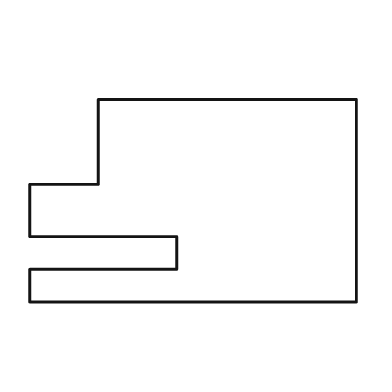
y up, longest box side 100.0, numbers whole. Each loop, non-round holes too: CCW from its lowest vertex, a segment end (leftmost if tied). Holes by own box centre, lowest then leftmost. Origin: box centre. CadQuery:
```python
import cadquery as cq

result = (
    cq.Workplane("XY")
    .moveTo(-50.0, -31.0)
    .lineTo(50.0, -31.0)
    .lineTo(50.0, 31.0)
    .lineTo(-29.0, 31.0)
    .lineTo(-29.0, 5.0)
    .lineTo(-50.0, 5.0)
    .lineTo(-50.0, -11.0)
    .lineTo(-5.0, -11.0)
    .lineTo(-5.0, -21.0)
    .lineTo(-50.0, -21.0)
    .close()
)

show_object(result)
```